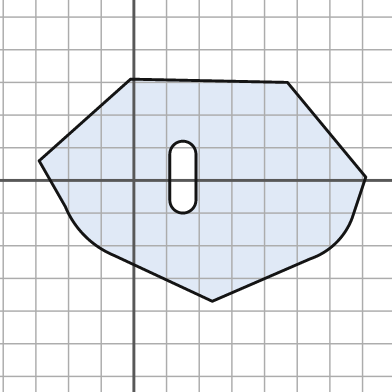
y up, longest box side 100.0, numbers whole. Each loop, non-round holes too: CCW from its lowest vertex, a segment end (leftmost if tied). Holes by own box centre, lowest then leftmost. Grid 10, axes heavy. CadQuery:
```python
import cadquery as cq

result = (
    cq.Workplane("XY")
    .moveTo(24.0, -37.0)
    .lineTo(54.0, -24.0)
    .threePointArc((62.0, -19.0), (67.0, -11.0))
    .lineTo(71.0, 1.0)
    .lineTo(47.0, 30.0)
    .lineTo(-1.0, 31.0)
    .lineTo(-29.0, 6.0)
    .lineTo(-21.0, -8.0)
    .threePointArc((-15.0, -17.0), (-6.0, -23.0))
    .close()
    .moveTo(11.0, -6.0)
    .threePointArc((15.0, -10.0), (19.0, -6.0))
    .lineTo(19.0, 8.0)
    .threePointArc((15.0, 12.0), (11.0, 8.0))
    .close()
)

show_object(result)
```